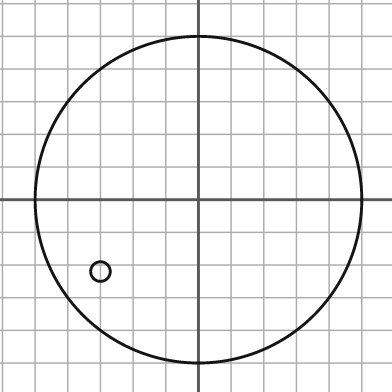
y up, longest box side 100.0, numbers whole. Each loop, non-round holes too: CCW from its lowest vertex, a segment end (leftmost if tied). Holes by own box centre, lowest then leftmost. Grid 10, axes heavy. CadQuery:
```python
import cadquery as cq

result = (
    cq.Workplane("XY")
    .moveTo(0.0, 0.0)
    .circle(50.0)
    .moveTo(-30.0, -22.0)
    .circle(3.0)
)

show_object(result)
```